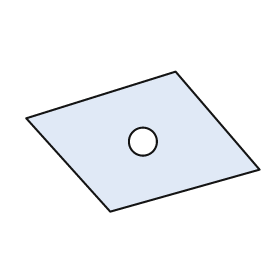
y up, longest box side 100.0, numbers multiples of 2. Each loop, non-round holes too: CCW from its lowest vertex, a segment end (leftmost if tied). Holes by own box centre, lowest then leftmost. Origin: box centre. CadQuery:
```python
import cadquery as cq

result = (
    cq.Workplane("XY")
    .moveTo(-14.0, -30.0)
    .lineTo(50.0, -12.0)
    .lineTo(14.0, 30.0)
    .lineTo(-50.0, 10.0)
    .close()
    .moveTo(0.0, 0.0)
    .circle(6.0)
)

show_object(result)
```